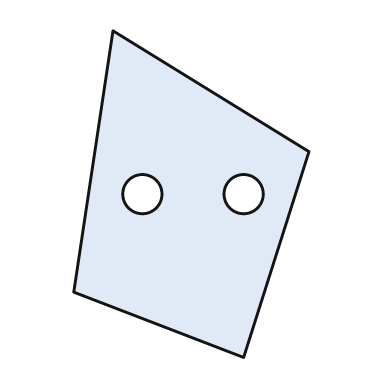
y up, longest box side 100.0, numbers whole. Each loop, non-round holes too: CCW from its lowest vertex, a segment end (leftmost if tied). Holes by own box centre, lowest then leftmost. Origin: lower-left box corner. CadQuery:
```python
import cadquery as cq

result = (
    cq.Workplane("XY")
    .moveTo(52.0, 0.0)
    .lineTo(72.0, 63.0)
    .lineTo(12.0, 100.0)
    .lineTo(0.0, 20.0)
    .close()
    .moveTo(21.0, 50.0)
    .circle(6.0)
    .moveTo(52.0, 50.0)
    .circle(6.0)
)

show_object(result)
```